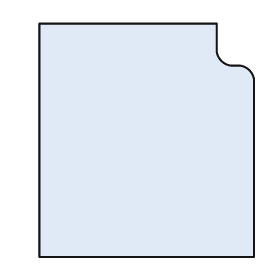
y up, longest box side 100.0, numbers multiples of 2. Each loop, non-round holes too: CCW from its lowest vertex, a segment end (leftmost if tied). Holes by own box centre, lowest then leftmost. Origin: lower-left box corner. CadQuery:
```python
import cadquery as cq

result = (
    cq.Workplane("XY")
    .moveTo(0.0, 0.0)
    .lineTo(92.0, 0.0)
    .lineTo(92.0, 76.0)
    .threePointArc((90.0, 80.0), (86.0, 82.0))
    .lineTo(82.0, 82.0)
    .threePointArc((78.0, 84.0), (76.0, 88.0))
    .lineTo(76.0, 100.0)
    .lineTo(0.0, 100.0)
    .close()
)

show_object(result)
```